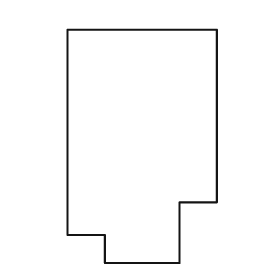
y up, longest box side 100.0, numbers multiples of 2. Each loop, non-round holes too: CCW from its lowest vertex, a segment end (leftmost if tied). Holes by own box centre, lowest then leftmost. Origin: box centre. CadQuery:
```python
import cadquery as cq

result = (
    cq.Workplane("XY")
    .moveTo(-16.0, -50.0)
    .lineTo(16.0, -50.0)
    .lineTo(16.0, -24.0)
    .lineTo(32.0, -24.0)
    .lineTo(32.0, 50.0)
    .lineTo(-32.0, 50.0)
    .lineTo(-32.0, -38.0)
    .lineTo(-16.0, -38.0)
    .close()
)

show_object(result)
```